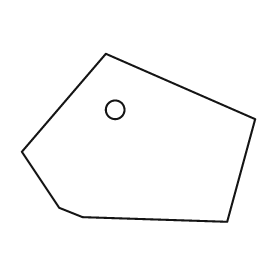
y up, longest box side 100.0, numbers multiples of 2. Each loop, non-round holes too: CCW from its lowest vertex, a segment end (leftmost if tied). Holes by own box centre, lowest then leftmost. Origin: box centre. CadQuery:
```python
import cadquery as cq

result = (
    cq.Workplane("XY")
    .moveTo(38.0, -36.0)
    .lineTo(50.0, 8.0)
    .lineTo(-14.0, 36.0)
    .lineTo(-50.0, -6.0)
    .lineTo(-34.0, -30.0)
    .lineTo(-24.0, -34.0)
    .close()
    .moveTo(-10.0, 12.0)
    .circle(4.0)
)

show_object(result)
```